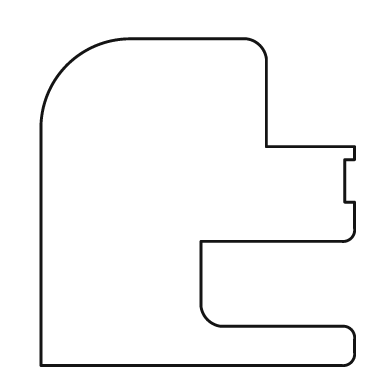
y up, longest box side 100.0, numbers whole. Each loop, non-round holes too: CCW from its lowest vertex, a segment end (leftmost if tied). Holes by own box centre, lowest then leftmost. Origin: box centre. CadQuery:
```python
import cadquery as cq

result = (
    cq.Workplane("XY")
    .moveTo(-48.0, -50.0)
    .lineTo(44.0, -50.0)
    .threePointArc((47.0, -49.0), (48.0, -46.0))
    .lineTo(48.0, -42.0)
    .threePointArc((47.0, -39.0), (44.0, -38.0))
    .lineTo(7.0, -38.0)
    .threePointArc((3.0, -36.0), (1.0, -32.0))
    .lineTo(1.0, -12.0)
    .lineTo(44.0, -12.0)
    .threePointArc((47.0, -11.0), (48.0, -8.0))
    .lineTo(48.0, 0.0)
    .lineTo(45.0, 0.0)
    .lineTo(45.0, 13.0)
    .lineTo(48.0, 13.0)
    .lineTo(48.0, 17.0)
    .lineTo(21.0, 17.0)
    .lineTo(21.0, 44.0)
    .threePointArc((19.0, 48.0), (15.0, 50.0))
    .lineTo(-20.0, 50.0)
    .threePointArc((-40.0, 42.0), (-48.0, 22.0))
    .close()
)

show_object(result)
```